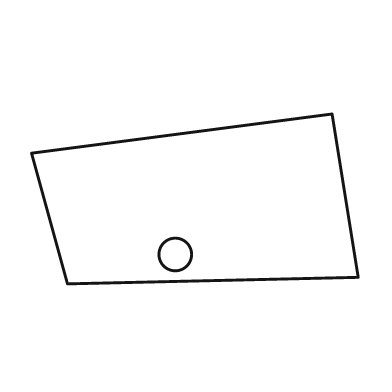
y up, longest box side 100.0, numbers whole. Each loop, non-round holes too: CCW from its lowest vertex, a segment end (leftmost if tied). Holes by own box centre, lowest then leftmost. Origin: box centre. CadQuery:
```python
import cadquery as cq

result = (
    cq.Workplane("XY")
    .moveTo(-39.0, -26.0)
    .lineTo(50.0, -24.0)
    .lineTo(42.0, 26.0)
    .lineTo(-50.0, 14.0)
    .close()
    .moveTo(-6.0, -17.0)
    .circle(5.0)
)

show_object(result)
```